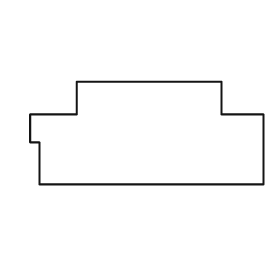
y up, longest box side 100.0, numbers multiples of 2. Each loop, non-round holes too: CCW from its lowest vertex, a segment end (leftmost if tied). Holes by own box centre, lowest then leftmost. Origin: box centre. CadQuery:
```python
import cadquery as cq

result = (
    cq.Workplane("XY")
    .moveTo(-46.0, -22.0)
    .lineTo(50.0, -22.0)
    .lineTo(50.0, 8.0)
    .lineTo(32.0, 8.0)
    .lineTo(32.0, 22.0)
    .lineTo(-30.0, 22.0)
    .lineTo(-30.0, 8.0)
    .lineTo(-50.0, 8.0)
    .lineTo(-50.0, -4.0)
    .lineTo(-46.0, -4.0)
    .close()
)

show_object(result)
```